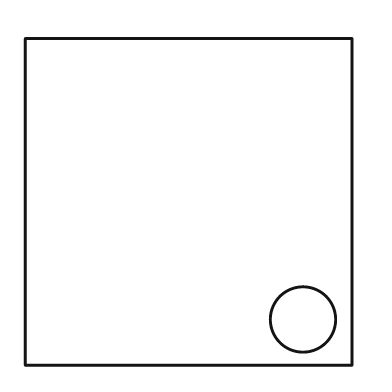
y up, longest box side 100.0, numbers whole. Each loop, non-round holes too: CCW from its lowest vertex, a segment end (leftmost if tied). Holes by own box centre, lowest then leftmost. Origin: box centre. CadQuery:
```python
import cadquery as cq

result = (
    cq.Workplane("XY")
    .moveTo(-50.0, -50.0)
    .lineTo(50.0, -50.0)
    .lineTo(50.0, 50.0)
    .lineTo(-50.0, 50.0)
    .close()
    .moveTo(35.0, -36.0)
    .circle(10.0)
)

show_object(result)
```